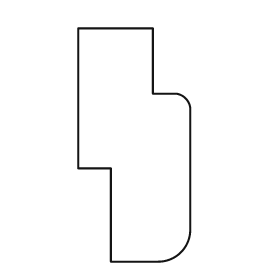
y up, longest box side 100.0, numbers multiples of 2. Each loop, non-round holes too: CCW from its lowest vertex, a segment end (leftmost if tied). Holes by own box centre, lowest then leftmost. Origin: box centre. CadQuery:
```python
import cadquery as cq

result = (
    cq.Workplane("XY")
    .moveTo(-10.0, -50.0)
    .lineTo(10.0, -50.0)
    .threePointArc((20.0, -46.0), (24.0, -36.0))
    .lineTo(24.0, 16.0)
    .threePointArc((22.0, 20.0), (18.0, 22.0))
    .lineTo(8.0, 22.0)
    .lineTo(8.0, 50.0)
    .lineTo(-24.0, 50.0)
    .lineTo(-24.0, -10.0)
    .lineTo(-10.0, -10.0)
    .close()
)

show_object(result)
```